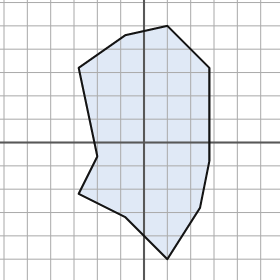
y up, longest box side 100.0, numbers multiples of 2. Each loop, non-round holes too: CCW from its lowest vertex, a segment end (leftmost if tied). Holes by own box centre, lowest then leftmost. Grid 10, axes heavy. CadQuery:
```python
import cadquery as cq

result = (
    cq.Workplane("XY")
    .moveTo(10.0, -50.0)
    .lineTo(24.0, -28.0)
    .lineTo(28.0, -8.0)
    .lineTo(28.0, 32.0)
    .lineTo(10.0, 50.0)
    .lineTo(-8.0, 46.0)
    .lineTo(-28.0, 32.0)
    .lineTo(-20.0, -6.0)
    .lineTo(-28.0, -22.0)
    .lineTo(-8.0, -32.0)
    .close()
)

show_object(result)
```